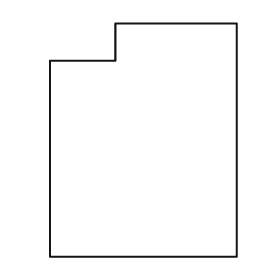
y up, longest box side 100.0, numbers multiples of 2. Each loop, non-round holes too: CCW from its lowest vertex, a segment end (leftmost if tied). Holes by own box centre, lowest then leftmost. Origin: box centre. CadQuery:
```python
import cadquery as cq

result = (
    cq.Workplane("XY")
    .moveTo(-40.0, -50.0)
    .lineTo(40.0, -50.0)
    .lineTo(40.0, 50.0)
    .lineTo(-12.0, 50.0)
    .lineTo(-12.0, 34.0)
    .lineTo(-40.0, 34.0)
    .close()
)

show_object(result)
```